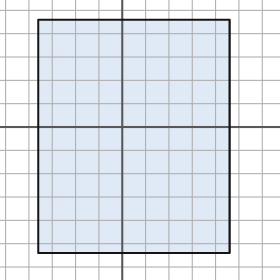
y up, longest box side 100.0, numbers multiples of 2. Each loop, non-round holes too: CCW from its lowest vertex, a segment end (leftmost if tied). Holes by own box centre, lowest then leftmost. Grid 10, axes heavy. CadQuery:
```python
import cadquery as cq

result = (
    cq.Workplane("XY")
    .moveTo(-36.0, -54.0)
    .lineTo(46.0, -54.0)
    .lineTo(46.0, 46.0)
    .lineTo(-36.0, 46.0)
    .close()
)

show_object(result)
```